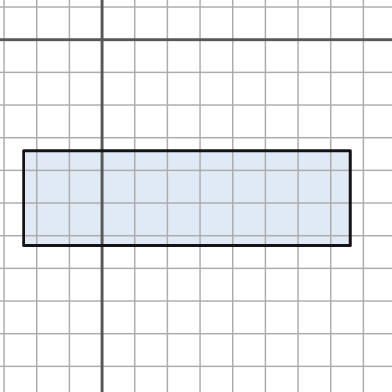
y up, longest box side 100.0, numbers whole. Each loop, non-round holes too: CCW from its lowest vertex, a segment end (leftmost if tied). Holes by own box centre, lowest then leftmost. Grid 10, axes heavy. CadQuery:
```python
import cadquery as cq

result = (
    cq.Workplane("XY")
    .moveTo(-24.0, -63.0)
    .lineTo(76.0, -63.0)
    .lineTo(76.0, -34.0)
    .lineTo(-24.0, -34.0)
    .close()
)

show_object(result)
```